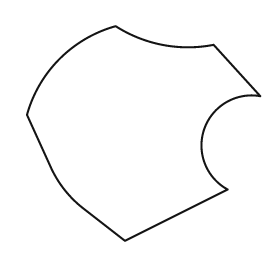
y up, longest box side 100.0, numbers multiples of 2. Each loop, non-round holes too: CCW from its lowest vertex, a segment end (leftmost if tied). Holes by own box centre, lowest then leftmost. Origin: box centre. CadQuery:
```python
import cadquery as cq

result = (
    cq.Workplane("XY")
    .moveTo(-8.0, -46.0)
    .lineTo(36.0, -24.0)
    .threePointArc((26.0, 2.0), (50.0, 16.0))
    .lineTo(30.0, 38.0)
    .threePointArc((8.0, 38.0), (-12.0, 46.0))
    .threePointArc((-36.0, 32.0), (-50.0, 8.0))
    .lineTo(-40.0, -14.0)
    .threePointArc((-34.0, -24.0), (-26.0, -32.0))
    .close()
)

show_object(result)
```